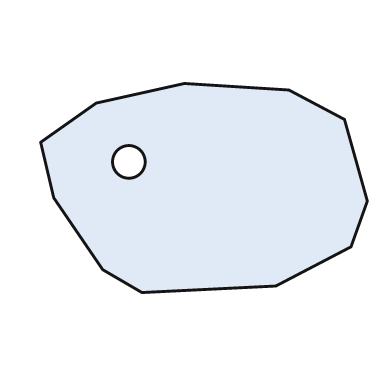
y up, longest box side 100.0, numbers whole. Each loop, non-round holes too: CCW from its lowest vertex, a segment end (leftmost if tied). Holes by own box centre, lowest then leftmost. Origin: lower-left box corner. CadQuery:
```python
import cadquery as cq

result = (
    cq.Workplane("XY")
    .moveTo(31.0, 0.0)
    .lineTo(72.0, 2.0)
    .lineTo(95.0, 14.0)
    .lineTo(100.0, 28.0)
    .lineTo(93.0, 53.0)
    .lineTo(76.0, 62.0)
    .lineTo(44.0, 64.0)
    .lineTo(17.0, 58.0)
    .lineTo(0.0, 46.0)
    .lineTo(4.0, 29.0)
    .lineTo(19.0, 7.0)
    .close()
    .moveTo(27.0, 40.0)
    .circle(5.0)
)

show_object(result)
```